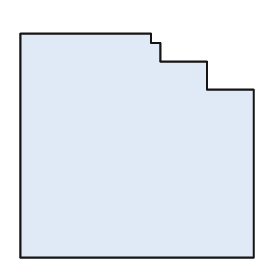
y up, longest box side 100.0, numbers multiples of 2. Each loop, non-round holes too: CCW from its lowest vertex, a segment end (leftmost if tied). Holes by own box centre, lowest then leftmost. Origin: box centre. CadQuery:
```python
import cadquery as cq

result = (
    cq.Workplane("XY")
    .moveTo(-50.0, -48.0)
    .lineTo(50.0, -48.0)
    .lineTo(50.0, 24.0)
    .lineTo(30.0, 24.0)
    .lineTo(30.0, 36.0)
    .lineTo(10.0, 36.0)
    .lineTo(10.0, 44.0)
    .lineTo(6.0, 44.0)
    .lineTo(6.0, 48.0)
    .lineTo(-50.0, 48.0)
    .close()
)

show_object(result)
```